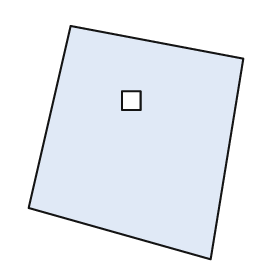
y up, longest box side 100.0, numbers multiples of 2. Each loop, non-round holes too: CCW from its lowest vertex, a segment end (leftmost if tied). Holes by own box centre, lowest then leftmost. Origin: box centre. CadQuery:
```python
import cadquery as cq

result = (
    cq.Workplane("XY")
    .moveTo(32.0, -50.0)
    .lineTo(46.0, 36.0)
    .lineTo(-28.0, 50.0)
    .lineTo(-46.0, -28.0)
    .close()
    .moveTo(-6.0, 14.0)
    .lineTo(2.0, 14.0)
    .lineTo(2.0, 22.0)
    .lineTo(-6.0, 22.0)
    .close()
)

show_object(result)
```